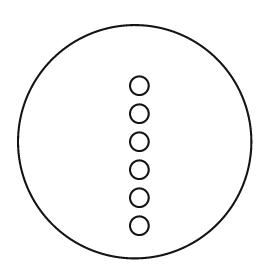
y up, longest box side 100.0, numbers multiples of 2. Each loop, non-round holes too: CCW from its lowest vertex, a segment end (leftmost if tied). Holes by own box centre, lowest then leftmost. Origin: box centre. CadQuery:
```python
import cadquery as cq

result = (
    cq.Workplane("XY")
    .moveTo(0.0, 0.0)
    .circle(50.0)
    .moveTo(2.0, -36.0)
    .circle(4.0)
    .moveTo(2.0, -24.0)
    .circle(4.0)
    .moveTo(2.0, -12.0)
    .circle(4.0)
    .moveTo(2.0, 0.0)
    .circle(4.0)
    .moveTo(2.0, 12.0)
    .circle(4.0)
    .moveTo(2.0, 24.0)
    .circle(4.0)
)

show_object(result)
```